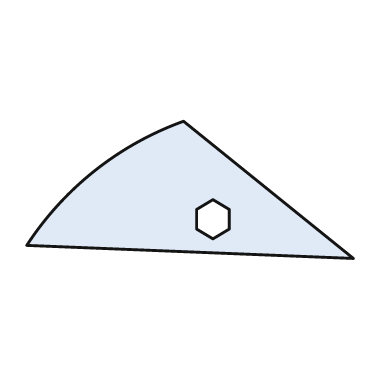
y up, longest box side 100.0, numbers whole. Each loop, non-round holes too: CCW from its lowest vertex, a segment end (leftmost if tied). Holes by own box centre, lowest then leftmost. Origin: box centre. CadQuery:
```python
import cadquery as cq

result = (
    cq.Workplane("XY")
    .moveTo(50.0, -21.0)
    .lineTo(-2.0, 21.0)
    .threePointArc((-29.0, 6.0), (-50.0, -17.0))
    .close()
    .moveTo(7.0, -15.0)
    .lineTo(12.0, -12.0)
    .lineTo(12.0, -6.0)
    .lineTo(7.0, -3.0)
    .lineTo(2.0, -6.0)
    .lineTo(2.0, -12.0)
    .close()
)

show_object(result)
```